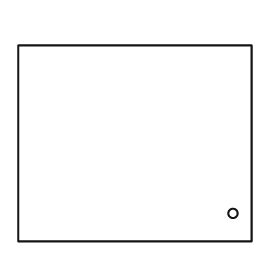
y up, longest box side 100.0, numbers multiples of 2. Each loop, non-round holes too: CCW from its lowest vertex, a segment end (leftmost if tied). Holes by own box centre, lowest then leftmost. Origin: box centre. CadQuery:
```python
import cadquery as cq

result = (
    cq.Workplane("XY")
    .moveTo(-50.0, -42.0)
    .lineTo(50.0, -42.0)
    .lineTo(50.0, 42.0)
    .lineTo(-50.0, 42.0)
    .close()
    .moveTo(42.0, -30.0)
    .circle(2.0)
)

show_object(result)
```